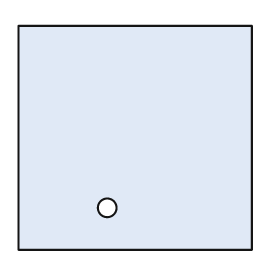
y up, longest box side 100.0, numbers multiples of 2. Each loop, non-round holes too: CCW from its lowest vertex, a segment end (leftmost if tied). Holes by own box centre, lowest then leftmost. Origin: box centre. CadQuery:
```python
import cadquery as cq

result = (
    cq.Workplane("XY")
    .moveTo(-50.0, -48.0)
    .lineTo(50.0, -48.0)
    .lineTo(50.0, 48.0)
    .lineTo(-50.0, 48.0)
    .close()
    .moveTo(-12.0, -30.0)
    .circle(4.0)
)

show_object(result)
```